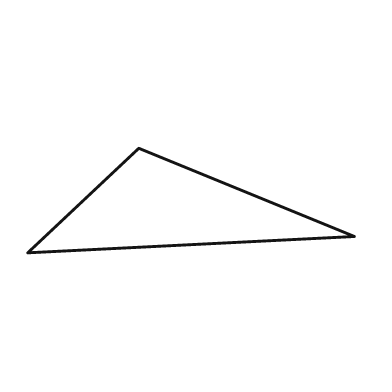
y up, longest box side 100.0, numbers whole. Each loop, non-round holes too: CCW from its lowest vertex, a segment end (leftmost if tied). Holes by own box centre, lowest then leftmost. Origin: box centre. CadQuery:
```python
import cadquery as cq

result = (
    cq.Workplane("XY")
    .moveTo(-50.0, -16.0)
    .lineTo(50.0, -11.0)
    .lineTo(-16.0, 16.0)
    .close()
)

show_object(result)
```